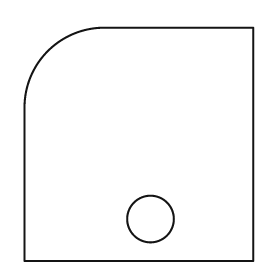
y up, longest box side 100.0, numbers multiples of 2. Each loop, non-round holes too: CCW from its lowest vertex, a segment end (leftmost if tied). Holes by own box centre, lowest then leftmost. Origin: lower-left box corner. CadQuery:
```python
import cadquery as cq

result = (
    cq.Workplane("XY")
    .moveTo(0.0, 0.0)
    .lineTo(98.0, 0.0)
    .lineTo(98.0, 100.0)
    .lineTo(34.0, 100.0)
    .threePointArc((10.0, 90.0), (0.0, 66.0))
    .close()
    .moveTo(54.0, 18.0)
    .circle(10.0)
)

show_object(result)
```